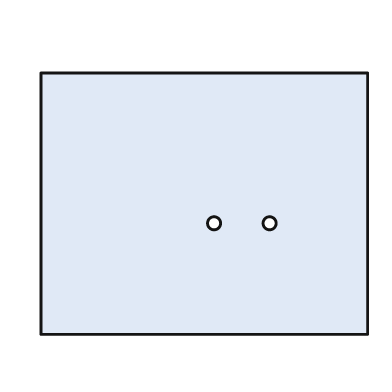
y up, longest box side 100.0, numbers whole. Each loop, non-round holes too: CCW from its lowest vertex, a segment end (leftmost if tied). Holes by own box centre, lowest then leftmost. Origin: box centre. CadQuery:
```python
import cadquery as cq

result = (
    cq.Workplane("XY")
    .moveTo(-50.0, -40.0)
    .lineTo(50.0, -40.0)
    .lineTo(50.0, 40.0)
    .lineTo(-50.0, 40.0)
    .close()
    .moveTo(3.0, -6.0)
    .circle(2.0)
    .moveTo(20.0, -6.0)
    .circle(2.0)
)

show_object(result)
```